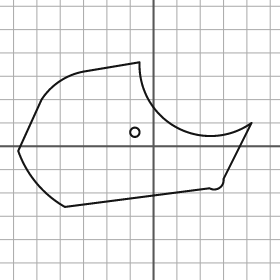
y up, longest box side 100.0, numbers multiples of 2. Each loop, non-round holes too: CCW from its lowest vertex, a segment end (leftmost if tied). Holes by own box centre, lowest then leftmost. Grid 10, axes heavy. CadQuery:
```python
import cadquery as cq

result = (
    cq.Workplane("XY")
    .moveTo(-38.0, -26.0)
    .lineTo(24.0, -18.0)
    .threePointArc((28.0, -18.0), (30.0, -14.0))
    .lineTo(42.0, 10.0)
    .threePointArc((10.0, 8.0), (-6.0, 36.0))
    .lineTo(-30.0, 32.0)
    .threePointArc((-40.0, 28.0), (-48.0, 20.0))
    .lineTo(-58.0, -2.0)
    .threePointArc((-50.0, -16.0), (-38.0, -26.0))
    .close()
    .moveTo(-8.0, 6.0)
    .circle(2.0)
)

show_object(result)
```